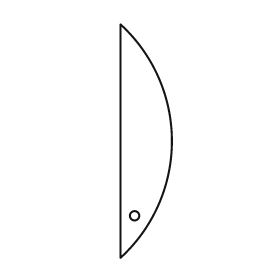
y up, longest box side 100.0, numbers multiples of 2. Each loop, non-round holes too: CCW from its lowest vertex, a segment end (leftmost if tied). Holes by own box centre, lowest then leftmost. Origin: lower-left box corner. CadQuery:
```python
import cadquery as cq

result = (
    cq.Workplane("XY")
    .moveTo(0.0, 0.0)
    .threePointArc((22.0, 50.0), (0.0, 100.0))
    .close()
    .moveTo(6.0, 18.0)
    .circle(2.0)
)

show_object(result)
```